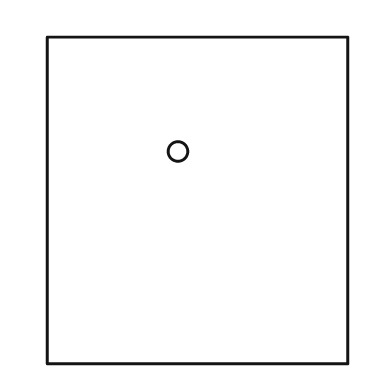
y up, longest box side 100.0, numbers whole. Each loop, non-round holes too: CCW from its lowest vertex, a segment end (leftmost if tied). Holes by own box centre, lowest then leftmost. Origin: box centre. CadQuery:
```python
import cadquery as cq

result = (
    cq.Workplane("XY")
    .moveTo(-46.0, -50.0)
    .lineTo(46.0, -50.0)
    .lineTo(46.0, 50.0)
    .lineTo(-46.0, 50.0)
    .close()
    .moveTo(-6.0, 15.0)
    .circle(3.0)
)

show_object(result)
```